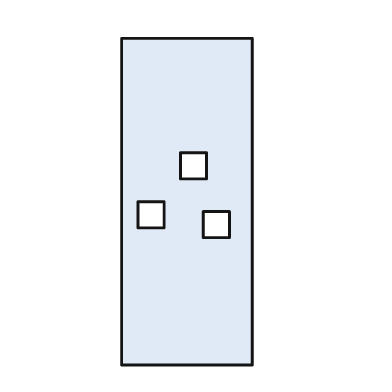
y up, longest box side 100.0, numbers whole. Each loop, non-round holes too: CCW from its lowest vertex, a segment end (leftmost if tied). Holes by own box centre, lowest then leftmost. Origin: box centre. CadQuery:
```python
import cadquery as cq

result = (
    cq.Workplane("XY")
    .moveTo(-20.0, -50.0)
    .lineTo(20.0, -50.0)
    .lineTo(20.0, 50.0)
    .lineTo(-20.0, 50.0)
    .close()
    .moveTo(5.0, -11.0)
    .lineTo(13.0, -11.0)
    .lineTo(13.0, -3.0)
    .lineTo(5.0, -3.0)
    .close()
    .moveTo(-15.0, -8.0)
    .lineTo(-7.0, -8.0)
    .lineTo(-7.0, 0.0)
    .lineTo(-15.0, 0.0)
    .close()
    .moveTo(-2.0, 7.0)
    .lineTo(6.0, 7.0)
    .lineTo(6.0, 15.0)
    .lineTo(-2.0, 15.0)
    .close()
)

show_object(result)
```